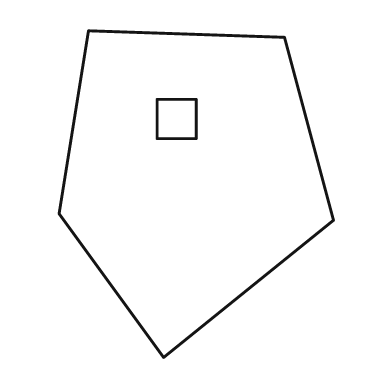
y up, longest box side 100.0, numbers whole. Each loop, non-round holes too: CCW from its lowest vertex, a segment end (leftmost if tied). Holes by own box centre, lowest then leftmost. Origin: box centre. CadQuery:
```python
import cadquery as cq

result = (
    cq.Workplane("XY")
    .moveTo(-10.0, -50.0)
    .lineTo(42.0, -8.0)
    .lineTo(27.0, 48.0)
    .lineTo(-33.0, 50.0)
    .lineTo(-42.0, -6.0)
    .close()
    .moveTo(-12.0, 17.0)
    .lineTo(0.0, 17.0)
    .lineTo(0.0, 29.0)
    .lineTo(-12.0, 29.0)
    .close()
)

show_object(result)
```